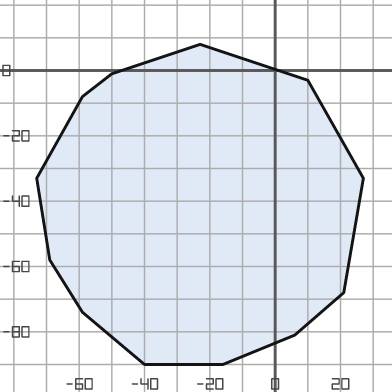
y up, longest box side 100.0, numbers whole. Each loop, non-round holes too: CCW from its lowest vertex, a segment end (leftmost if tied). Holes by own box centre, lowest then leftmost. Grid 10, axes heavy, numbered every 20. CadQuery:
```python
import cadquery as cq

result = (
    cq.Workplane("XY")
    .moveTo(-40.0, -90.0)
    .lineTo(-16.0, -90.0)
    .lineTo(6.0, -81.0)
    .lineTo(21.0, -68.0)
    .lineTo(27.0, -33.0)
    .lineTo(10.0, -3.0)
    .lineTo(-23.0, 8.0)
    .lineTo(-50.0, -1.0)
    .lineTo(-59.0, -8.0)
    .lineTo(-73.0, -33.0)
    .lineTo(-69.0, -58.0)
    .lineTo(-59.0, -74.0)
    .close()
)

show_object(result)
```